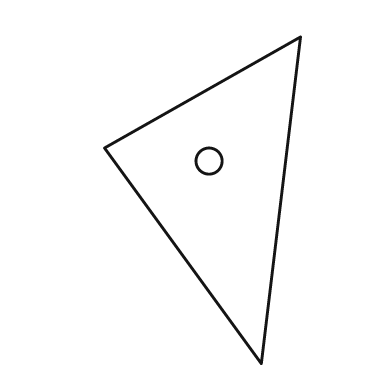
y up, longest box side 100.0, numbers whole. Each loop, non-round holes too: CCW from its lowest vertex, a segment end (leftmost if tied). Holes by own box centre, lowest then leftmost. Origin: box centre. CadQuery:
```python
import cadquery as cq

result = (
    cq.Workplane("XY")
    .moveTo(18.0, -50.0)
    .lineTo(30.0, 50.0)
    .lineTo(-30.0, 16.0)
    .close()
    .moveTo(2.0, 12.0)
    .circle(4.0)
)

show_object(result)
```